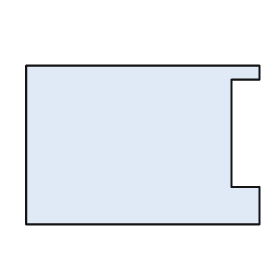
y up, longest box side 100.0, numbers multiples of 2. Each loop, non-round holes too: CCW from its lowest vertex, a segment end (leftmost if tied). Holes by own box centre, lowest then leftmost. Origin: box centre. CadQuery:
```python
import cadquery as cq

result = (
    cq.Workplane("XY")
    .moveTo(-50.0, -34.0)
    .lineTo(50.0, -34.0)
    .lineTo(50.0, -18.0)
    .lineTo(38.0, -18.0)
    .lineTo(38.0, 28.0)
    .lineTo(50.0, 28.0)
    .lineTo(50.0, 34.0)
    .lineTo(-50.0, 34.0)
    .close()
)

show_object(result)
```